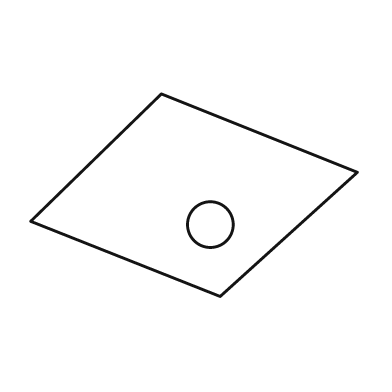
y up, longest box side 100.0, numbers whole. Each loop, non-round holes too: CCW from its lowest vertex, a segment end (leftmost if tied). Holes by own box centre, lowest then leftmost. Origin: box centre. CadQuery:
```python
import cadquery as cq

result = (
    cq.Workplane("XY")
    .moveTo(8.0, -31.0)
    .lineTo(50.0, 7.0)
    .lineTo(-10.0, 31.0)
    .lineTo(-50.0, -8.0)
    .close()
    .moveTo(5.0, -9.0)
    .circle(7.0)
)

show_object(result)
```